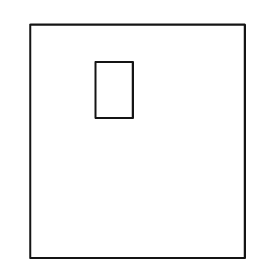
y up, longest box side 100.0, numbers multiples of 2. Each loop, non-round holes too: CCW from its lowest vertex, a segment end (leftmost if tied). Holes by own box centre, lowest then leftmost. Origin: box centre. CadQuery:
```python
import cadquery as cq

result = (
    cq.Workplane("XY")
    .moveTo(-46.0, -50.0)
    .lineTo(46.0, -50.0)
    .lineTo(46.0, 50.0)
    .lineTo(-46.0, 50.0)
    .close()
    .moveTo(-18.0, 10.0)
    .lineTo(-2.0, 10.0)
    .lineTo(-2.0, 34.0)
    .lineTo(-18.0, 34.0)
    .close()
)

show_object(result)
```